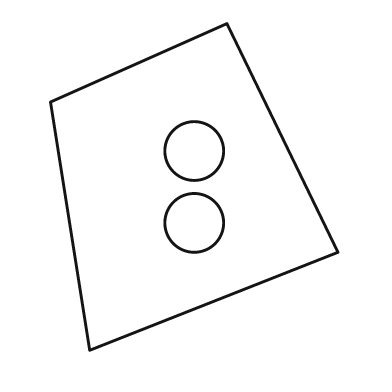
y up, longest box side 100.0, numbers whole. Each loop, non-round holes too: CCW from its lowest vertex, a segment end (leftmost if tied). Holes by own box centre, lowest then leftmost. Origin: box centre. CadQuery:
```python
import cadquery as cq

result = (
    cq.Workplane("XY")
    .moveTo(-32.0, -50.0)
    .lineTo(44.0, -20.0)
    .lineTo(10.0, 50.0)
    .lineTo(-44.0, 26.0)
    .close()
    .moveTo(0.0, -11.0)
    .circle(9.0)
    .moveTo(0.0, 11.0)
    .circle(9.0)
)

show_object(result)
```